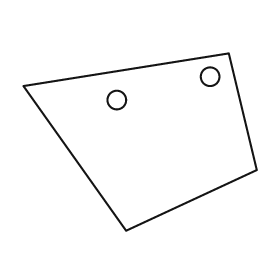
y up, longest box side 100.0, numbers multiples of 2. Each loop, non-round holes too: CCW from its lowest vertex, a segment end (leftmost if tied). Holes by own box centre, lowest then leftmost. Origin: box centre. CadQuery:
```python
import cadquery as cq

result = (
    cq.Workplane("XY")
    .moveTo(-6.0, -38.0)
    .lineTo(50.0, -12.0)
    .lineTo(38.0, 38.0)
    .lineTo(-50.0, 24.0)
    .close()
    .moveTo(-10.0, 18.0)
    .circle(4.0)
    .moveTo(30.0, 28.0)
    .circle(4.0)
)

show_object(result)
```